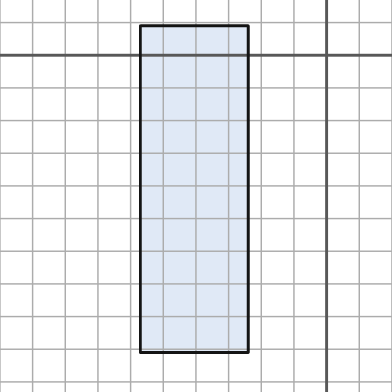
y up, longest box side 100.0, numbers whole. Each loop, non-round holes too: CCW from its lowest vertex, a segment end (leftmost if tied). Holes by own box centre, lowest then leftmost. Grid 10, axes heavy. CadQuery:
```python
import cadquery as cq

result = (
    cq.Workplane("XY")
    .moveTo(-57.0, -91.0)
    .lineTo(-24.0, -91.0)
    .lineTo(-24.0, 9.0)
    .lineTo(-57.0, 9.0)
    .close()
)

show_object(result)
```